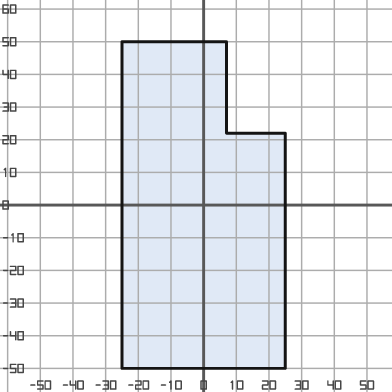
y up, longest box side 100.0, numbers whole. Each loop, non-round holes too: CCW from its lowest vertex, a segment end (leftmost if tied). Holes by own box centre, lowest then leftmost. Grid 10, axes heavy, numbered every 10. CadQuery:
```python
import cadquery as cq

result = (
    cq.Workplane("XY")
    .moveTo(-25.0, -50.0)
    .lineTo(25.0, -50.0)
    .lineTo(25.0, 22.0)
    .lineTo(7.0, 22.0)
    .lineTo(7.0, 50.0)
    .lineTo(-25.0, 50.0)
    .close()
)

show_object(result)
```